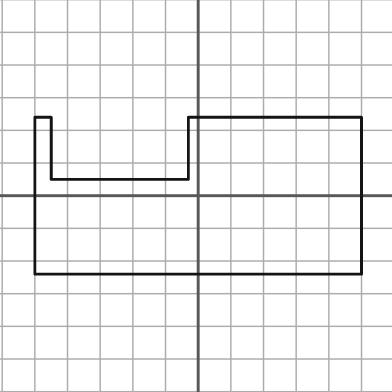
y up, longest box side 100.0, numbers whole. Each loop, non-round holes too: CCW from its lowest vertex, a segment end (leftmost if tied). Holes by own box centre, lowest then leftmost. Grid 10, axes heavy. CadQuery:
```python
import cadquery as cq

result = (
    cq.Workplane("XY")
    .moveTo(-50.0, -24.0)
    .lineTo(50.0, -24.0)
    .lineTo(50.0, 24.0)
    .lineTo(-3.0, 24.0)
    .lineTo(-3.0, 5.0)
    .lineTo(-45.0, 5.0)
    .lineTo(-45.0, 24.0)
    .lineTo(-50.0, 24.0)
    .close()
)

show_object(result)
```